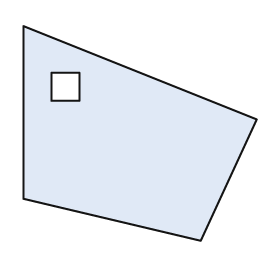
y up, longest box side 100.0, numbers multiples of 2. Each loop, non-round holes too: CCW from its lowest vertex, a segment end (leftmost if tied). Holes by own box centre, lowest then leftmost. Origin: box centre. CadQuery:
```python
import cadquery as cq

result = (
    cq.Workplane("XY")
    .moveTo(26.0, -46.0)
    .lineTo(50.0, 6.0)
    .lineTo(-50.0, 46.0)
    .lineTo(-50.0, -28.0)
    .close()
    .moveTo(-38.0, 14.0)
    .lineTo(-26.0, 14.0)
    .lineTo(-26.0, 26.0)
    .lineTo(-38.0, 26.0)
    .close()
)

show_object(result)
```